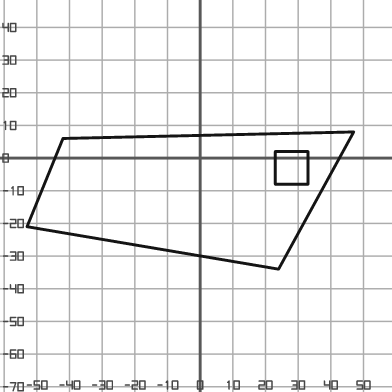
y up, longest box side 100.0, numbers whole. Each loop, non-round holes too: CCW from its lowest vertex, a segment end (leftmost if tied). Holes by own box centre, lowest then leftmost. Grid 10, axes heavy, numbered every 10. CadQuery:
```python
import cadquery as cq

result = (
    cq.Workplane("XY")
    .moveTo(24.0, -34.0)
    .lineTo(47.0, 8.0)
    .lineTo(-42.0, 6.0)
    .lineTo(-53.0, -21.0)
    .close()
    .moveTo(23.0, -8.0)
    .lineTo(33.0, -8.0)
    .lineTo(33.0, 2.0)
    .lineTo(23.0, 2.0)
    .close()
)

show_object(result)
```